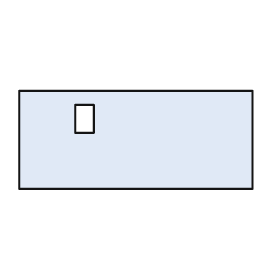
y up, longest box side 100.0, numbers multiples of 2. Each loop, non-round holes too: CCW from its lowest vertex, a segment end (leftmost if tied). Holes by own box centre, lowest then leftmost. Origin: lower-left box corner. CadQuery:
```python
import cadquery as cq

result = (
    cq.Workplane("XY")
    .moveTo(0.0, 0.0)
    .lineTo(100.0, 0.0)
    .lineTo(100.0, 42.0)
    .lineTo(0.0, 42.0)
    .close()
    .moveTo(24.0, 24.0)
    .lineTo(32.0, 24.0)
    .lineTo(32.0, 36.0)
    .lineTo(24.0, 36.0)
    .close()
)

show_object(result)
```